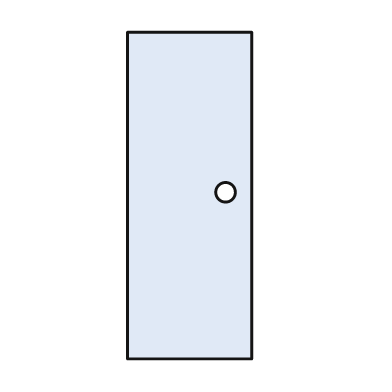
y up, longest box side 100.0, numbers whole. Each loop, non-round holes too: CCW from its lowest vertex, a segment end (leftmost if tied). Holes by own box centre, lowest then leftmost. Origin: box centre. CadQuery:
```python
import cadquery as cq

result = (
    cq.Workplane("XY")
    .moveTo(-19.0, -50.0)
    .lineTo(19.0, -50.0)
    .lineTo(19.0, 50.0)
    .lineTo(-19.0, 50.0)
    .close()
    .moveTo(11.0, 1.0)
    .circle(3.0)
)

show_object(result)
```